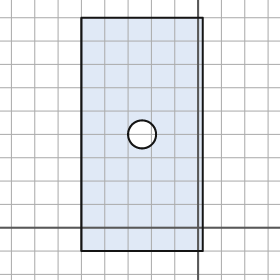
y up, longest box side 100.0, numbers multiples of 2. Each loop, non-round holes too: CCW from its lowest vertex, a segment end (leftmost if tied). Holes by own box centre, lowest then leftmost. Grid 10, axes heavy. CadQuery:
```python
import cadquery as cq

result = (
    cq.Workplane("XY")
    .moveTo(-50.0, -10.0)
    .lineTo(2.0, -10.0)
    .lineTo(2.0, 90.0)
    .lineTo(-50.0, 90.0)
    .close()
    .moveTo(-24.0, 40.0)
    .circle(6.0)
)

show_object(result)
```